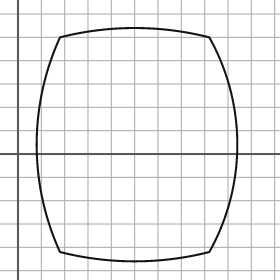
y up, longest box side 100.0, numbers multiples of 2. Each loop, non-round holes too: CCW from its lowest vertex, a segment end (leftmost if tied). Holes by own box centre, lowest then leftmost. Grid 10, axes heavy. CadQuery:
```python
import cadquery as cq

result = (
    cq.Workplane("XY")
    .moveTo(18.0, -42.0)
    .threePointArc((50.0, -46.0), (82.0, -42.0))
    .threePointArc((94.0, 4.0), (82.0, 50.0))
    .threePointArc((50.0, 54.0), (18.0, 50.0))
    .threePointArc((8.0, 4.0), (18.0, -42.0))
    .close()
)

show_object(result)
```